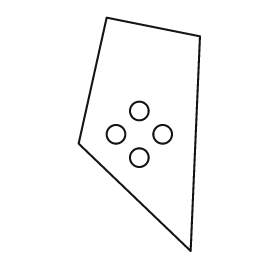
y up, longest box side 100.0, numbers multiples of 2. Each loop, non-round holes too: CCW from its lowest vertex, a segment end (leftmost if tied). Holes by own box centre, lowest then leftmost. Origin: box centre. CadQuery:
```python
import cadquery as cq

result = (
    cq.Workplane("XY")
    .moveTo(22.0, -50.0)
    .lineTo(26.0, 42.0)
    .lineTo(-14.0, 50.0)
    .lineTo(-26.0, -4.0)
    .close()
    .moveTo(0.0, -10.0)
    .circle(4.0)
    .moveTo(-10.0, 0.0)
    .circle(4.0)
    .moveTo(10.0, 0.0)
    .circle(4.0)
    .moveTo(0.0, 10.0)
    .circle(4.0)
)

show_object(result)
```